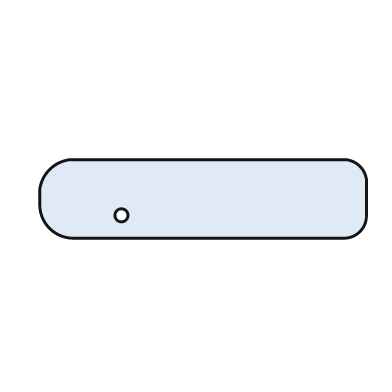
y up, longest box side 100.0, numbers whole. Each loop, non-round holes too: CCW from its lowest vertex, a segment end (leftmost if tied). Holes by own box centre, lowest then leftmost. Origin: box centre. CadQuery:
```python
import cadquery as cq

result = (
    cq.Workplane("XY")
    .moveTo(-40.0, -12.0)
    .lineTo(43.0, -12.0)
    .threePointArc((48.0, -10.0), (50.0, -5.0))
    .lineTo(50.0, 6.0)
    .threePointArc((48.0, 10.0), (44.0, 12.0))
    .lineTo(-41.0, 12.0)
    .threePointArc((-47.0, 9.0), (-50.0, 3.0))
    .lineTo(-50.0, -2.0)
    .threePointArc((-47.0, -9.0), (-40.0, -12.0))
    .close()
    .moveTo(-25.0, -5.0)
    .circle(2.0)
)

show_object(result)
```